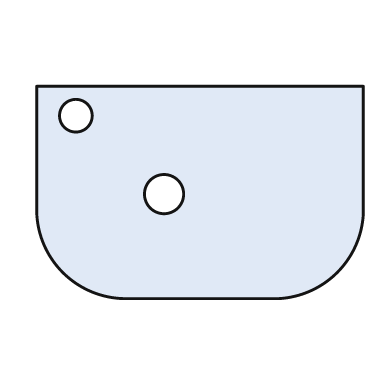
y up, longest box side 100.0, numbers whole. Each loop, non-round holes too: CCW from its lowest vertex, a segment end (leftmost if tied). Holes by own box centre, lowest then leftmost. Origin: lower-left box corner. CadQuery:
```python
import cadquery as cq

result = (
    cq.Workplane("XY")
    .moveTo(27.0, 0.0)
    .lineTo(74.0, 0.0)
    .threePointArc((92.0, 8.0), (100.0, 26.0))
    .lineTo(100.0, 65.0)
    .lineTo(0.0, 65.0)
    .lineTo(0.0, 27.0)
    .threePointArc((8.0, 8.0), (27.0, 0.0))
    .close()
    .moveTo(39.0, 32.0)
    .circle(6.0)
    .moveTo(12.0, 56.0)
    .circle(5.0)
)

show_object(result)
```